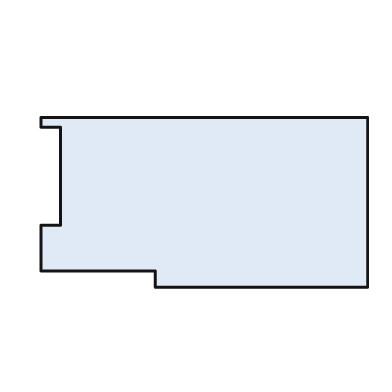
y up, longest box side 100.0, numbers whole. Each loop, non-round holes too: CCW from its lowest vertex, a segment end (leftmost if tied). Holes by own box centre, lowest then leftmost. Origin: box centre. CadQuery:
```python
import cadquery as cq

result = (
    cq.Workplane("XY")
    .moveTo(-15.0, -26.0)
    .lineTo(50.0, -26.0)
    .lineTo(50.0, 26.0)
    .lineTo(-50.0, 26.0)
    .lineTo(-50.0, 23.0)
    .lineTo(-44.0, 23.0)
    .lineTo(-44.0, -7.0)
    .lineTo(-50.0, -7.0)
    .lineTo(-50.0, -21.0)
    .lineTo(-15.0, -21.0)
    .close()
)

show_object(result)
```